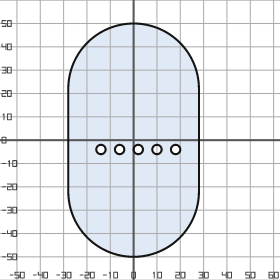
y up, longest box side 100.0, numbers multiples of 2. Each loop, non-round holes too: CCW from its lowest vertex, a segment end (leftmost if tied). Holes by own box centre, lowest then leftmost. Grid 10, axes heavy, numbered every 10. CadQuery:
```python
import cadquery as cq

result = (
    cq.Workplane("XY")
    .moveTo(-28.0, -22.0)
    .threePointArc((0.0, -50.0), (28.0, -22.0))
    .lineTo(28.0, 22.0)
    .threePointArc((0.0, 50.0), (-28.0, 22.0))
    .close()
    .moveTo(-14.0, -4.0)
    .circle(2.0)
    .moveTo(-6.0, -4.0)
    .circle(2.0)
    .moveTo(2.0, -4.0)
    .circle(2.0)
    .moveTo(10.0, -4.0)
    .circle(2.0)
    .moveTo(18.0, -4.0)
    .circle(2.0)
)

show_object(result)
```